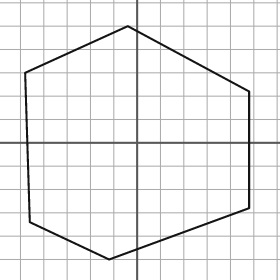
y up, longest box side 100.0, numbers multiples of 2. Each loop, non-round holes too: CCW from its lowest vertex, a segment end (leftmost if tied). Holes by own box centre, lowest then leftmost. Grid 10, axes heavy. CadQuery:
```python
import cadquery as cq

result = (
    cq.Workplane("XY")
    .moveTo(-12.0, -50.0)
    .lineTo(48.0, -28.0)
    .lineTo(48.0, 22.0)
    .lineTo(-4.0, 50.0)
    .lineTo(-48.0, 30.0)
    .lineTo(-46.0, -34.0)
    .close()
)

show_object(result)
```